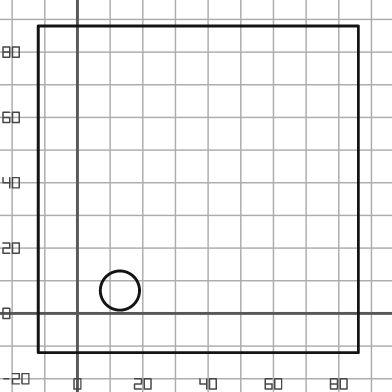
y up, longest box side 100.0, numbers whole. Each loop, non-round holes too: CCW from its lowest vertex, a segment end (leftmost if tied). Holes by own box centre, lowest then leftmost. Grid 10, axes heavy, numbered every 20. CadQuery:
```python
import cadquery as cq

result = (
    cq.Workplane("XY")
    .moveTo(-12.0, -12.0)
    .lineTo(86.0, -12.0)
    .lineTo(86.0, 88.0)
    .lineTo(-12.0, 88.0)
    .close()
    .moveTo(13.0, 7.0)
    .circle(6.0)
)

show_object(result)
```